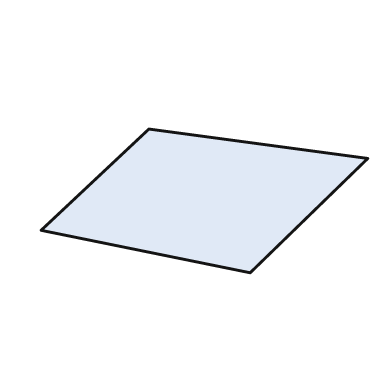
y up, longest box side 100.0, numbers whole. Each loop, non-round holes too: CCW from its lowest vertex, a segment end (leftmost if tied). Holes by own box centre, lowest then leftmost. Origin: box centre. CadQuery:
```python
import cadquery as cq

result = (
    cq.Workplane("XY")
    .moveTo(14.0, -22.0)
    .lineTo(50.0, 13.0)
    .lineTo(-17.0, 22.0)
    .lineTo(-50.0, -9.0)
    .close()
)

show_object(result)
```